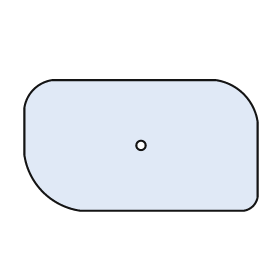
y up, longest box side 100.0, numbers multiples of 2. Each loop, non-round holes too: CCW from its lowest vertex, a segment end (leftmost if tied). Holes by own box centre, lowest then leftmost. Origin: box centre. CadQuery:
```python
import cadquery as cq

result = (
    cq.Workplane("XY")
    .moveTo(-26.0, -28.0)
    .lineTo(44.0, -28.0)
    .threePointArc((48.0, -26.0), (50.0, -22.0))
    .lineTo(50.0, 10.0)
    .threePointArc((44.0, 22.0), (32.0, 28.0))
    .lineTo(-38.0, 28.0)
    .threePointArc((-46.0, 24.0), (-50.0, 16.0))
    .lineTo(-50.0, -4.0)
    .threePointArc((-42.0, -20.0), (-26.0, -28.0))
    .close()
    .moveTo(0.0, 0.0)
    .circle(2.0)
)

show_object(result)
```